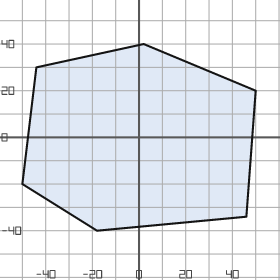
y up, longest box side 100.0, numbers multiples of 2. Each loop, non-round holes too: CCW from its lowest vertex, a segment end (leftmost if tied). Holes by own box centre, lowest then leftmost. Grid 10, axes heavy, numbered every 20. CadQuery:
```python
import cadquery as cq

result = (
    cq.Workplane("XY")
    .moveTo(-18.0, -40.0)
    .lineTo(46.0, -34.0)
    .lineTo(50.0, 20.0)
    .lineTo(2.0, 40.0)
    .lineTo(-44.0, 30.0)
    .lineTo(-50.0, -20.0)
    .close()
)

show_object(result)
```